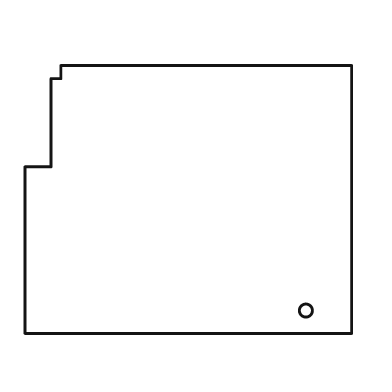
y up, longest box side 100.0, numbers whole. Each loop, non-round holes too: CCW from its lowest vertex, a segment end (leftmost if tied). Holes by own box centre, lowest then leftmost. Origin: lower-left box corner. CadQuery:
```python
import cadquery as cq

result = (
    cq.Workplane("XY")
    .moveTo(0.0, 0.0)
    .lineTo(100.0, 0.0)
    .lineTo(100.0, 82.0)
    .lineTo(11.0, 82.0)
    .lineTo(11.0, 78.0)
    .lineTo(8.0, 78.0)
    .lineTo(8.0, 51.0)
    .lineTo(0.0, 51.0)
    .close()
    .moveTo(86.0, 7.0)
    .circle(2.0)
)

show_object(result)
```